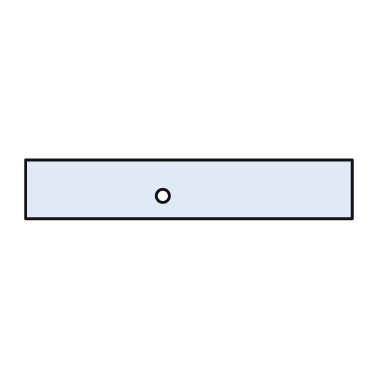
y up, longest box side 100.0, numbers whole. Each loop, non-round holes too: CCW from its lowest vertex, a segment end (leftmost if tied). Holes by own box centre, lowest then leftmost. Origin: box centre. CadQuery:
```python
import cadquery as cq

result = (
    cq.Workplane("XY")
    .moveTo(-50.0, -9.0)
    .lineTo(50.0, -9.0)
    .lineTo(50.0, 9.0)
    .lineTo(-50.0, 9.0)
    .close()
    .moveTo(-8.0, -2.0)
    .circle(2.0)
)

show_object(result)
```